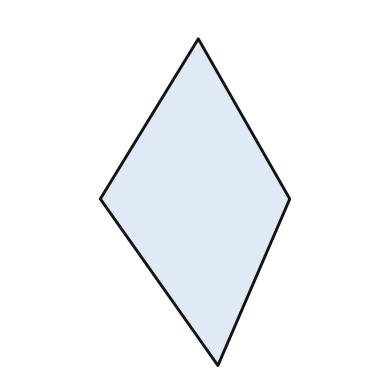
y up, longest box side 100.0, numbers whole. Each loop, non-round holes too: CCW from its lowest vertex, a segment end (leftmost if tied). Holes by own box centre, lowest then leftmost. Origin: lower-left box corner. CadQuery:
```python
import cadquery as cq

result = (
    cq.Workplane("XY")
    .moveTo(36.0, 0.0)
    .lineTo(58.0, 51.0)
    .lineTo(30.0, 100.0)
    .lineTo(0.0, 51.0)
    .close()
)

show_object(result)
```